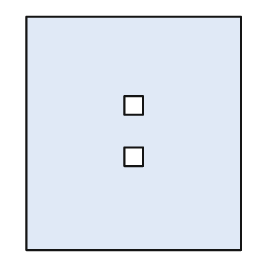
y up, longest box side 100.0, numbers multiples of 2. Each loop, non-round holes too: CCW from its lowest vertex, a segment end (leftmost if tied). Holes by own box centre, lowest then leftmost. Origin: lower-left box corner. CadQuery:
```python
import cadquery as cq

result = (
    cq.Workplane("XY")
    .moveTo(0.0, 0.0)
    .lineTo(92.0, 0.0)
    .lineTo(92.0, 100.0)
    .lineTo(0.0, 100.0)
    .close()
    .moveTo(42.0, 36.0)
    .lineTo(50.0, 36.0)
    .lineTo(50.0, 44.0)
    .lineTo(42.0, 44.0)
    .close()
    .moveTo(42.0, 58.0)
    .lineTo(50.0, 58.0)
    .lineTo(50.0, 66.0)
    .lineTo(42.0, 66.0)
    .close()
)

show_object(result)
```